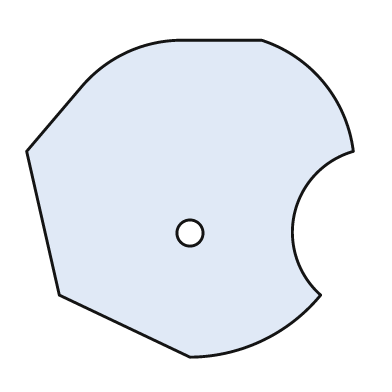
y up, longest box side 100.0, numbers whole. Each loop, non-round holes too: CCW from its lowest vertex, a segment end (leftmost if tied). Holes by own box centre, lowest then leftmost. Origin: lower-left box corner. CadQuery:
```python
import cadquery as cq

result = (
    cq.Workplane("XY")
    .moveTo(50.0, 0.0)
    .threePointArc((72.0, 5.0), (90.0, 19.0))
    .threePointArc((82.0, 44.0), (100.0, 63.0))
    .threePointArc((91.0, 84.0), (72.0, 97.0))
    .lineTo(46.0, 97.0)
    .threePointArc((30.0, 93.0), (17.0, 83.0))
    .lineTo(0.0, 63.0)
    .lineTo(10.0, 19.0)
    .close()
    .moveTo(50.0, 38.0)
    .circle(4.0)
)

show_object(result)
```